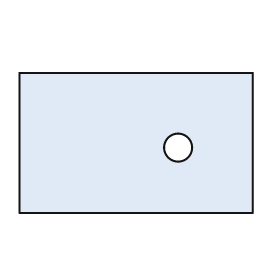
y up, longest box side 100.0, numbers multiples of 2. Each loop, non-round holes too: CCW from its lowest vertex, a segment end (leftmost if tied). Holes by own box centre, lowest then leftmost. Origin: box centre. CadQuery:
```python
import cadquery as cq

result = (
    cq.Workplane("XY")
    .moveTo(-50.0, -30.0)
    .lineTo(50.0, -30.0)
    .lineTo(50.0, 30.0)
    .lineTo(-50.0, 30.0)
    .close()
    .moveTo(18.0, -2.0)
    .circle(6.0)
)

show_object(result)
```